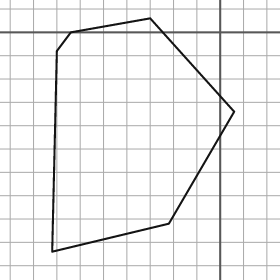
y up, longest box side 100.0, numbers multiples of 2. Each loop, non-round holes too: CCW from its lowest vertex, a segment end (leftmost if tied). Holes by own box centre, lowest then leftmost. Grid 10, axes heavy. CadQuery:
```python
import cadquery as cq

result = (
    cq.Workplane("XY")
    .moveTo(-72.0, -94.0)
    .lineTo(-22.0, -82.0)
    .lineTo(6.0, -34.0)
    .lineTo(-30.0, 6.0)
    .lineTo(-64.0, 0.0)
    .lineTo(-70.0, -8.0)
    .close()
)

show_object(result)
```